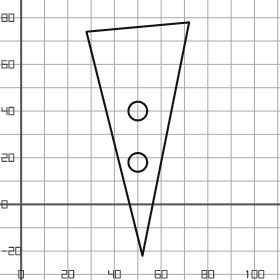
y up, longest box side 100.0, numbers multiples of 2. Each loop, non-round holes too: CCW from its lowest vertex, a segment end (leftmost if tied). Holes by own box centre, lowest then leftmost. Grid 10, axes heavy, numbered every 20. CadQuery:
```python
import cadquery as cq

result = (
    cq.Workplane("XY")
    .moveTo(52.0, -22.0)
    .lineTo(72.0, 78.0)
    .lineTo(28.0, 74.0)
    .close()
    .moveTo(50.0, 18.0)
    .circle(4.0)
    .moveTo(50.0, 40.0)
    .circle(4.0)
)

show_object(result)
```